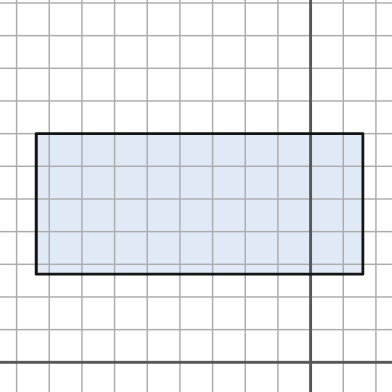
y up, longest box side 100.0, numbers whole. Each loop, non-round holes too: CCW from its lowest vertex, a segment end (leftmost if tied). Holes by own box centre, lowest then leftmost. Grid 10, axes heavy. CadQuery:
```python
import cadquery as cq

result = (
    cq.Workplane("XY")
    .moveTo(-84.0, 27.0)
    .lineTo(16.0, 27.0)
    .lineTo(16.0, 70.0)
    .lineTo(-84.0, 70.0)
    .close()
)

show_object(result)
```